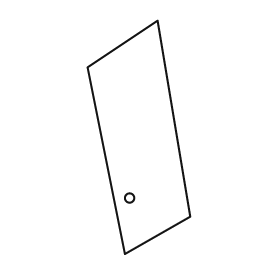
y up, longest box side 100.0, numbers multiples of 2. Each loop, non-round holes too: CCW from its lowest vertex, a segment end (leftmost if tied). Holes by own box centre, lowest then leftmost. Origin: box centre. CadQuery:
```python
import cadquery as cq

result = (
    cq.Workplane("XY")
    .moveTo(-6.0, -50.0)
    .lineTo(22.0, -34.0)
    .lineTo(8.0, 50.0)
    .lineTo(-22.0, 30.0)
    .close()
    .moveTo(-4.0, -26.0)
    .circle(2.0)
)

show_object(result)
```